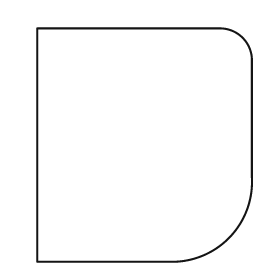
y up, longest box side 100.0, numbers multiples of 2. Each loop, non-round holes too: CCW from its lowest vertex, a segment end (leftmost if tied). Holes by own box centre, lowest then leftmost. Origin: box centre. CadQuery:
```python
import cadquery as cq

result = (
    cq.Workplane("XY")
    .moveTo(-46.0, -50.0)
    .lineTo(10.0, -50.0)
    .threePointArc((36.0, -40.0), (46.0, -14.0))
    .lineTo(46.0, 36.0)
    .threePointArc((42.0, 46.0), (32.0, 50.0))
    .lineTo(-46.0, 50.0)
    .close()
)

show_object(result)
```